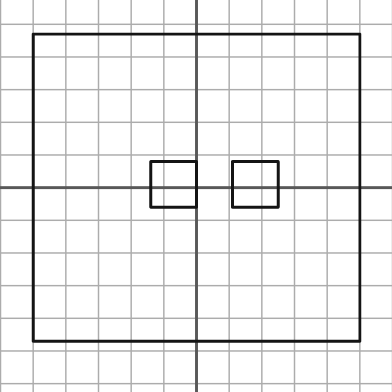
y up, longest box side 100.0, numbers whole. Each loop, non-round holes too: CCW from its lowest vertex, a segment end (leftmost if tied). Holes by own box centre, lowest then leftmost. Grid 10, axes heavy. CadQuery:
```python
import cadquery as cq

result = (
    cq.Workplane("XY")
    .moveTo(-50.0, -47.0)
    .lineTo(50.0, -47.0)
    .lineTo(50.0, 47.0)
    .lineTo(-50.0, 47.0)
    .close()
    .moveTo(-14.0, -6.0)
    .lineTo(0.0, -6.0)
    .lineTo(0.0, 8.0)
    .lineTo(-14.0, 8.0)
    .close()
    .moveTo(11.0, -6.0)
    .lineTo(25.0, -6.0)
    .lineTo(25.0, 8.0)
    .lineTo(11.0, 8.0)
    .close()
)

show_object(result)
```